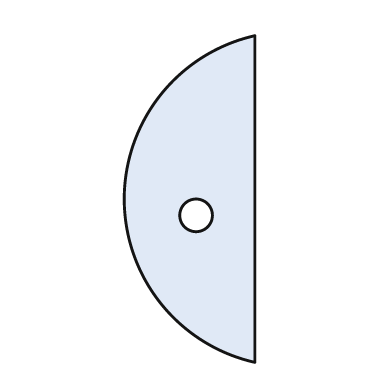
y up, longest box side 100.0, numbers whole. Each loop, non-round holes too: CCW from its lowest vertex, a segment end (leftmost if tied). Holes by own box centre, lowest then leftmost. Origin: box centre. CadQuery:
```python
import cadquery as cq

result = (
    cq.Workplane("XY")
    .moveTo(20.0, -50.0)
    .lineTo(20.0, 50.0)
    .threePointArc((-20.0, 0.0), (20.0, -50.0))
    .close()
    .moveTo(2.0, -5.0)
    .circle(5.0)
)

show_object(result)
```